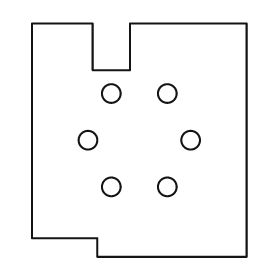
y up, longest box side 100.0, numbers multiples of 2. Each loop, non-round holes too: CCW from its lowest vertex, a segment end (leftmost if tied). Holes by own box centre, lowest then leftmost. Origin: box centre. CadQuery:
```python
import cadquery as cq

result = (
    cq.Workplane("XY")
    .moveTo(-18.0, -50.0)
    .lineTo(46.0, -50.0)
    .lineTo(46.0, 50.0)
    .lineTo(-4.0, 50.0)
    .lineTo(-4.0, 30.0)
    .lineTo(-20.0, 30.0)
    .lineTo(-20.0, 50.0)
    .lineTo(-46.0, 50.0)
    .lineTo(-46.0, -42.0)
    .lineTo(-18.0, -42.0)
    .close()
    .moveTo(-12.0, -20.0)
    .circle(4.0)
    .moveTo(12.0, -20.0)
    .circle(4.0)
    .moveTo(-22.0, 0.0)
    .circle(4.0)
    .moveTo(22.0, 0.0)
    .circle(4.0)
    .moveTo(-12.0, 20.0)
    .circle(4.0)
    .moveTo(12.0, 20.0)
    .circle(4.0)
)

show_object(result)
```